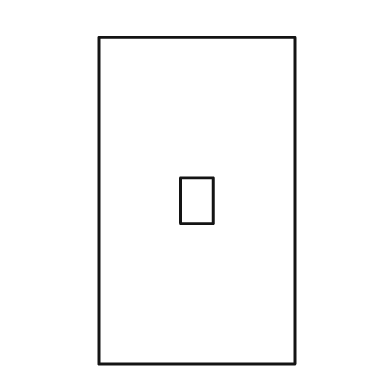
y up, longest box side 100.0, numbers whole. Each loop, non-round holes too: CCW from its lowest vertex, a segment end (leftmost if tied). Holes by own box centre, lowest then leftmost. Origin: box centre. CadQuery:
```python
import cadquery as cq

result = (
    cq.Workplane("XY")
    .moveTo(-30.0, -50.0)
    .lineTo(30.0, -50.0)
    .lineTo(30.0, 50.0)
    .lineTo(-30.0, 50.0)
    .close()
    .moveTo(-5.0, -7.0)
    .lineTo(5.0, -7.0)
    .lineTo(5.0, 7.0)
    .lineTo(-5.0, 7.0)
    .close()
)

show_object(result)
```